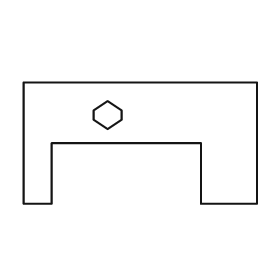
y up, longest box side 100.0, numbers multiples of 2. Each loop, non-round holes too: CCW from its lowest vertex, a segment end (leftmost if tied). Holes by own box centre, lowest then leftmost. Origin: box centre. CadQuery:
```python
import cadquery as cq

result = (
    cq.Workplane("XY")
    .moveTo(-50.0, -26.0)
    .lineTo(-38.0, -26.0)
    .lineTo(-38.0, 0.0)
    .lineTo(26.0, 0.0)
    .lineTo(26.0, -26.0)
    .lineTo(50.0, -26.0)
    .lineTo(50.0, 26.0)
    .lineTo(-50.0, 26.0)
    .close()
    .moveTo(-14.0, 6.0)
    .lineTo(-8.0, 10.0)
    .lineTo(-8.0, 14.0)
    .lineTo(-14.0, 18.0)
    .lineTo(-20.0, 14.0)
    .lineTo(-20.0, 10.0)
    .close()
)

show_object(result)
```